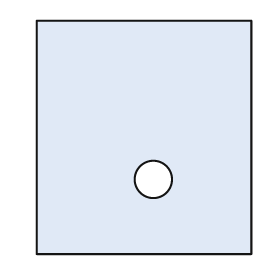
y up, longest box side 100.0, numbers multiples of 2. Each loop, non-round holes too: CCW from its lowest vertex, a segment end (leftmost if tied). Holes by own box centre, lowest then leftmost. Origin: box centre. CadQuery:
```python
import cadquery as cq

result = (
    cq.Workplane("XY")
    .moveTo(-46.0, -50.0)
    .lineTo(46.0, -50.0)
    .lineTo(46.0, 50.0)
    .lineTo(-46.0, 50.0)
    .close()
    .moveTo(4.0, -18.0)
    .circle(8.0)
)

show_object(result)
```